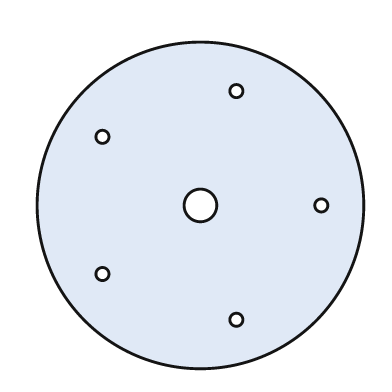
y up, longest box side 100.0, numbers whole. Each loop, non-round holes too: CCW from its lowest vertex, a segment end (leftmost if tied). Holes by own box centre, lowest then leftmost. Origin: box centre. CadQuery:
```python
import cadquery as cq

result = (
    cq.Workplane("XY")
    .moveTo(0.0, 0.0)
    .circle(50.0)
    .moveTo(11.0, -35.0)
    .circle(2.0)
    .moveTo(-30.0, -21.0)
    .circle(2.0)
    .moveTo(0.0, 0.0)
    .circle(5.0)
    .moveTo(37.0, 0.0)
    .circle(2.0)
    .moveTo(-30.0, 21.0)
    .circle(2.0)
    .moveTo(11.0, 35.0)
    .circle(2.0)
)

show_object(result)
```